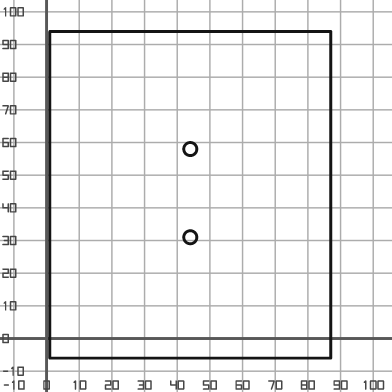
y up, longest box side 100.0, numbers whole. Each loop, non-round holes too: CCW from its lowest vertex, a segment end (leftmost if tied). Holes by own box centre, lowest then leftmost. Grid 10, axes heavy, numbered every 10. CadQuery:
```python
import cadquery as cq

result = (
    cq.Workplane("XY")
    .moveTo(1.0, -6.0)
    .lineTo(87.0, -6.0)
    .lineTo(87.0, 94.0)
    .lineTo(1.0, 94.0)
    .close()
    .moveTo(44.0, 31.0)
    .circle(2.0)
    .moveTo(44.0, 58.0)
    .circle(2.0)
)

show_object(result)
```